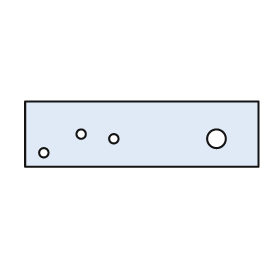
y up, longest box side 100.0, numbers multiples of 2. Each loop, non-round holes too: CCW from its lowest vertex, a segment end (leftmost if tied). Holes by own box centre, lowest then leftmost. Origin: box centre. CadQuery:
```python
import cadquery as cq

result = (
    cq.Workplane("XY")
    .moveTo(-50.0, -14.0)
    .lineTo(50.0, -14.0)
    .lineTo(50.0, 14.0)
    .lineTo(-50.0, 14.0)
    .close()
    .moveTo(-42.0, -8.0)
    .circle(2.0)
    .moveTo(-12.0, -2.0)
    .circle(2.0)
    .moveTo(32.0, -2.0)
    .circle(4.0)
    .moveTo(-26.0, 0.0)
    .circle(2.0)
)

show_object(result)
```